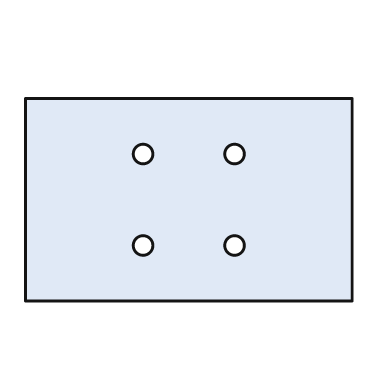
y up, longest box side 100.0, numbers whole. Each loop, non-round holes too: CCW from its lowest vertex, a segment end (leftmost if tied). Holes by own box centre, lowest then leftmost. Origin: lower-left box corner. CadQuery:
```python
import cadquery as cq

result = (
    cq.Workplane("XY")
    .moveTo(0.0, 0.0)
    .lineTo(100.0, 0.0)
    .lineTo(100.0, 62.0)
    .lineTo(0.0, 62.0)
    .close()
    .moveTo(36.0, 17.0)
    .circle(3.0)
    .moveTo(64.0, 17.0)
    .circle(3.0)
    .moveTo(36.0, 45.0)
    .circle(3.0)
    .moveTo(64.0, 45.0)
    .circle(3.0)
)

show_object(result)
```